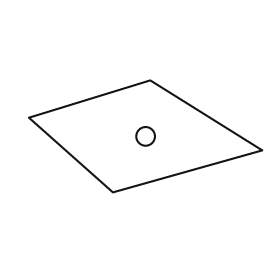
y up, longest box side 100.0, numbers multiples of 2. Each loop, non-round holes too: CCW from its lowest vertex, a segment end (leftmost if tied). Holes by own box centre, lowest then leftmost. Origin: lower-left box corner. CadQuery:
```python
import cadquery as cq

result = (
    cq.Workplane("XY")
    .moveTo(36.0, 0.0)
    .lineTo(100.0, 18.0)
    .lineTo(52.0, 48.0)
    .lineTo(0.0, 32.0)
    .close()
    .moveTo(50.0, 24.0)
    .circle(4.0)
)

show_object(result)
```